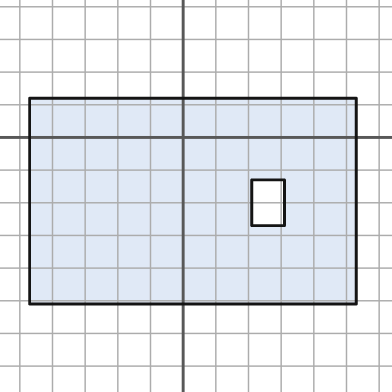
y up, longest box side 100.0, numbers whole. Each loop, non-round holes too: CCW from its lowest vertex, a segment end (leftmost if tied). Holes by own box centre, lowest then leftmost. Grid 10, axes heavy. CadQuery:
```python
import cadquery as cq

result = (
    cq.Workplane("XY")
    .moveTo(-47.0, -51.0)
    .lineTo(53.0, -51.0)
    .lineTo(53.0, 12.0)
    .lineTo(-47.0, 12.0)
    .close()
    .moveTo(21.0, -27.0)
    .lineTo(31.0, -27.0)
    .lineTo(31.0, -13.0)
    .lineTo(21.0, -13.0)
    .close()
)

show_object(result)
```